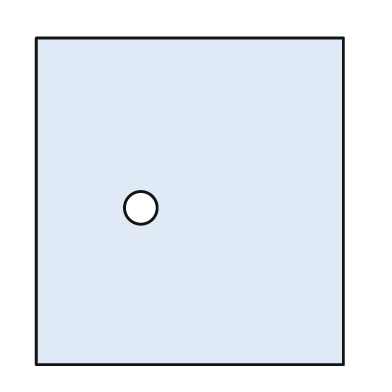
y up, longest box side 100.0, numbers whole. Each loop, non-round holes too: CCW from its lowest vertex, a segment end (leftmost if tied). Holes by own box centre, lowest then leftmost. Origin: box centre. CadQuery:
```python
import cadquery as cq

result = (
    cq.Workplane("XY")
    .moveTo(-47.0, -50.0)
    .lineTo(47.0, -50.0)
    .lineTo(47.0, 50.0)
    .lineTo(-47.0, 50.0)
    .close()
    .moveTo(-15.0, -2.0)
    .circle(5.0)
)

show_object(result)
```